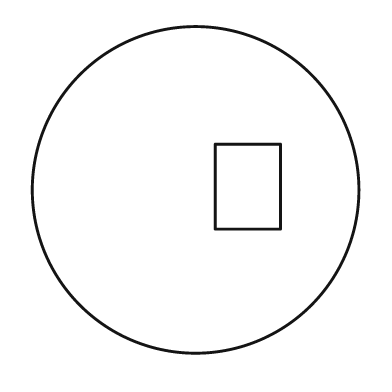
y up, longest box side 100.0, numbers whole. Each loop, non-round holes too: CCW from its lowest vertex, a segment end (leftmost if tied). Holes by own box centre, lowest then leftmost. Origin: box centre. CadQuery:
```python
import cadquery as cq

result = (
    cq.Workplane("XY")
    .moveTo(0.0, 0.0)
    .circle(50.0)
    .moveTo(6.0, -12.0)
    .lineTo(26.0, -12.0)
    .lineTo(26.0, 14.0)
    .lineTo(6.0, 14.0)
    .close()
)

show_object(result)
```